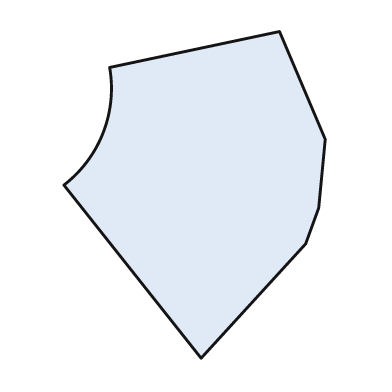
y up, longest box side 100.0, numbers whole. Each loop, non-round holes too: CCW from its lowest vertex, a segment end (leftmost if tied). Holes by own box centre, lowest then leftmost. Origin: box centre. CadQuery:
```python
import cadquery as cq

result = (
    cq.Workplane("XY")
    .moveTo(2.0, -50.0)
    .lineTo(34.0, -15.0)
    .lineTo(38.0, -4.0)
    .lineTo(40.0, 17.0)
    .lineTo(26.0, 50.0)
    .lineTo(-26.0, 39.0)
    .threePointArc((-28.0, 19.0), (-40.0, 3.0))
    .close()
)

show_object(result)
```